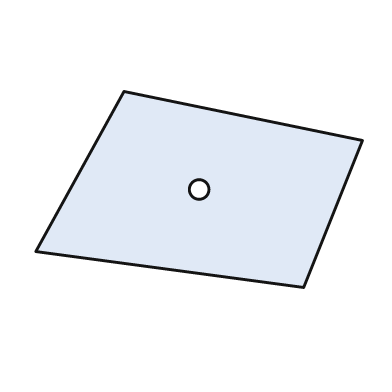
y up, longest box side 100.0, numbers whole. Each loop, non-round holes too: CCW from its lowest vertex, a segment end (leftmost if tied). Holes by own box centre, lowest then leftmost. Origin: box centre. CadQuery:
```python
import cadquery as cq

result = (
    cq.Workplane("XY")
    .moveTo(32.0, -30.0)
    .lineTo(50.0, 15.0)
    .lineTo(-23.0, 30.0)
    .lineTo(-50.0, -19.0)
    .close()
    .moveTo(0.0, 0.0)
    .circle(3.0)
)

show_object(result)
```